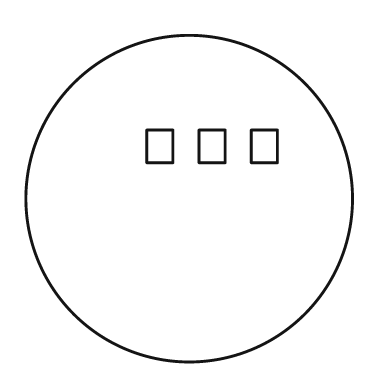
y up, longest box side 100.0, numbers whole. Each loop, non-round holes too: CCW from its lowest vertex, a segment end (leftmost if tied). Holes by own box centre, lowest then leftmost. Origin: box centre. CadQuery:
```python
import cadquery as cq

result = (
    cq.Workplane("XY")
    .moveTo(0.0, 0.0)
    .circle(50.0)
    .moveTo(-13.0, 11.0)
    .lineTo(-5.0, 11.0)
    .lineTo(-5.0, 21.0)
    .lineTo(-13.0, 21.0)
    .close()
    .moveTo(3.0, 11.0)
    .lineTo(11.0, 11.0)
    .lineTo(11.0, 21.0)
    .lineTo(3.0, 21.0)
    .close()
    .moveTo(19.0, 11.0)
    .lineTo(27.0, 11.0)
    .lineTo(27.0, 21.0)
    .lineTo(19.0, 21.0)
    .close()
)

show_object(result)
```